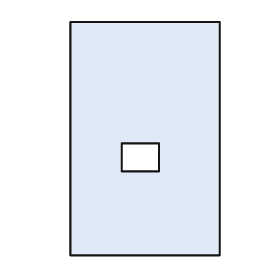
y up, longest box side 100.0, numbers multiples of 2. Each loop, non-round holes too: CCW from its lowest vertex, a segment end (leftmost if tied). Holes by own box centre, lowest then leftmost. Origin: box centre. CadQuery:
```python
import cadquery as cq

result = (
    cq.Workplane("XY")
    .moveTo(-32.0, -50.0)
    .lineTo(32.0, -50.0)
    .lineTo(32.0, 50.0)
    .lineTo(-32.0, 50.0)
    .close()
    .moveTo(-10.0, -14.0)
    .lineTo(6.0, -14.0)
    .lineTo(6.0, -2.0)
    .lineTo(-10.0, -2.0)
    .close()
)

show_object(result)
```